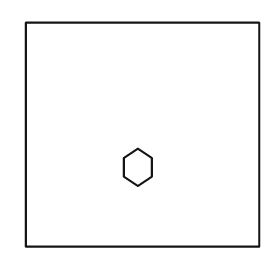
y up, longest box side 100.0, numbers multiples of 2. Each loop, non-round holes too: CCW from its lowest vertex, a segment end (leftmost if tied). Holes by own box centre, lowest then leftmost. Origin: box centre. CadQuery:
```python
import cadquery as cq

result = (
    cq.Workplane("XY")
    .moveTo(-50.0, -48.0)
    .lineTo(50.0, -48.0)
    .lineTo(50.0, 48.0)
    .lineTo(-50.0, 48.0)
    .close()
    .moveTo(-2.0, -22.0)
    .lineTo(4.0, -18.0)
    .lineTo(4.0, -10.0)
    .lineTo(-2.0, -6.0)
    .lineTo(-8.0, -10.0)
    .lineTo(-8.0, -18.0)
    .close()
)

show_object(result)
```